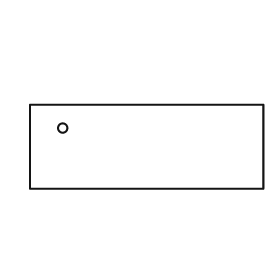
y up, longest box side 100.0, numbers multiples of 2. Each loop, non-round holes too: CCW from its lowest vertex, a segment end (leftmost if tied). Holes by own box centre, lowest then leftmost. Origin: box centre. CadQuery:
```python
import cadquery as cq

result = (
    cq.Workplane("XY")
    .moveTo(-50.0, -18.0)
    .lineTo(50.0, -18.0)
    .lineTo(50.0, 18.0)
    .lineTo(-50.0, 18.0)
    .close()
    .moveTo(-36.0, 8.0)
    .circle(2.0)
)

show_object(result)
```